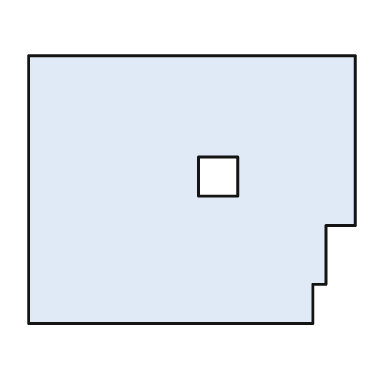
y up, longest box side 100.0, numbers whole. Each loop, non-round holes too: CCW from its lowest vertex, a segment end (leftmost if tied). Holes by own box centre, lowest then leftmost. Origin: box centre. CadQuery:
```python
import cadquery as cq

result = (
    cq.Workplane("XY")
    .moveTo(-50.0, -41.0)
    .lineTo(37.0, -41.0)
    .lineTo(37.0, -29.0)
    .lineTo(41.0, -29.0)
    .lineTo(41.0, -11.0)
    .lineTo(50.0, -11.0)
    .lineTo(50.0, 41.0)
    .lineTo(-50.0, 41.0)
    .close()
    .moveTo(2.0, -2.0)
    .lineTo(14.0, -2.0)
    .lineTo(14.0, 10.0)
    .lineTo(2.0, 10.0)
    .close()
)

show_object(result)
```